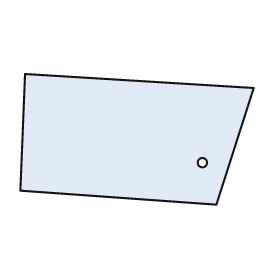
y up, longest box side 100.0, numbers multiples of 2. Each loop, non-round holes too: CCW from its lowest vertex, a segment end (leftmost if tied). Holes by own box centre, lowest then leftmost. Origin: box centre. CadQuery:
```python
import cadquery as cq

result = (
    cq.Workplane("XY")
    .moveTo(34.0, -28.0)
    .lineTo(50.0, 22.0)
    .lineTo(-48.0, 28.0)
    .lineTo(-50.0, -22.0)
    .close()
    .moveTo(28.0, -10.0)
    .circle(2.0)
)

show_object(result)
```